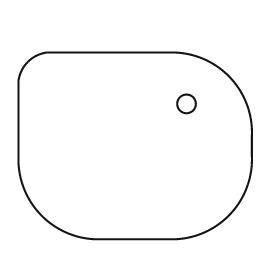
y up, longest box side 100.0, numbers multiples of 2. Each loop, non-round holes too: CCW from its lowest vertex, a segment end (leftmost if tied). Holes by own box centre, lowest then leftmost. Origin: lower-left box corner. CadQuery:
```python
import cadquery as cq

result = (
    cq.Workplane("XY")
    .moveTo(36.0, 0.0)
    .lineTo(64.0, 0.0)
    .threePointArc((90.0, 10.0), (100.0, 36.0))
    .lineTo(100.0, 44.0)
    .threePointArc((90.0, 70.0), (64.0, 80.0))
    .lineTo(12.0, 80.0)
    .threePointArc((4.0, 76.0), (0.0, 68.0))
    .lineTo(0.0, 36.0)
    .threePointArc((10.0, 10.0), (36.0, 0.0))
    .close()
    .moveTo(72.0, 58.0)
    .circle(4.0)
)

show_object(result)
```